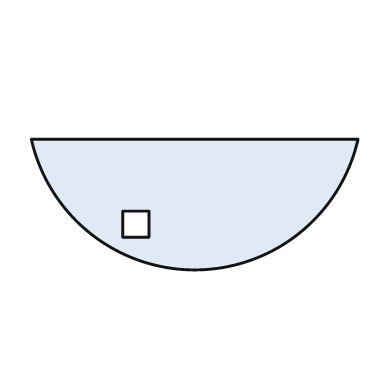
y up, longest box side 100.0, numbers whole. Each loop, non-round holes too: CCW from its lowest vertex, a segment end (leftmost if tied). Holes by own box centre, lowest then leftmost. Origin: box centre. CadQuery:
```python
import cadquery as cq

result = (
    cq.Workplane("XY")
    .moveTo(-50.0, 20.0)
    .threePointArc((0.0, -20.0), (50.0, 20.0))
    .close()
    .moveTo(-22.0, -10.0)
    .lineTo(-14.0, -10.0)
    .lineTo(-14.0, -2.0)
    .lineTo(-22.0, -2.0)
    .close()
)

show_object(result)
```